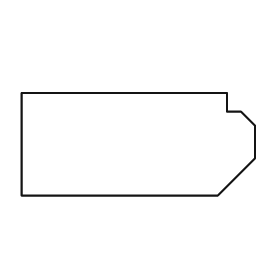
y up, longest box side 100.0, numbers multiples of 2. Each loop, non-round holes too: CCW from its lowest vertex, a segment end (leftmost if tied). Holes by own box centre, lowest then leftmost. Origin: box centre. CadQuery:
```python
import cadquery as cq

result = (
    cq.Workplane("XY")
    .moveTo(-50.0, -22.0)
    .lineTo(34.0, -22.0)
    .lineTo(50.0, -6.0)
    .lineTo(50.0, 8.0)
    .lineTo(44.0, 14.0)
    .lineTo(38.0, 14.0)
    .lineTo(38.0, 22.0)
    .lineTo(-50.0, 22.0)
    .close()
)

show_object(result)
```